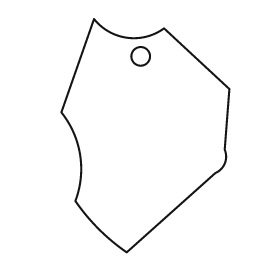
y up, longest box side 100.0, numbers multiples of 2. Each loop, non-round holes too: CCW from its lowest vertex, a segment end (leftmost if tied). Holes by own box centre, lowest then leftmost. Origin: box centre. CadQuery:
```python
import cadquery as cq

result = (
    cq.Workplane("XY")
    .moveTo(-8.0, -50.0)
    .lineTo(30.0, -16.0)
    .threePointArc((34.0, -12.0), (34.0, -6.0))
    .lineTo(36.0, 20.0)
    .lineTo(8.0, 46.0)
    .threePointArc((-8.0, 42.0), (-22.0, 50.0))
    .lineTo(-36.0, 10.0)
    .threePointArc((-28.0, -8.0), (-30.0, -28.0))
    .threePointArc((-20.0, -40.0), (-8.0, -50.0))
    .close()
    .moveTo(-2.0, 34.0)
    .circle(4.0)
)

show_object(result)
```